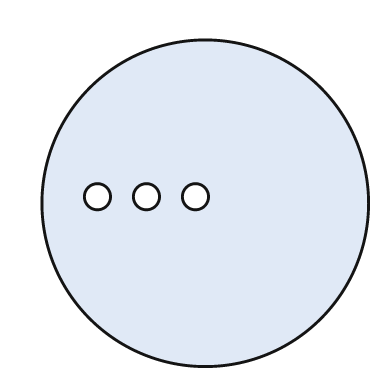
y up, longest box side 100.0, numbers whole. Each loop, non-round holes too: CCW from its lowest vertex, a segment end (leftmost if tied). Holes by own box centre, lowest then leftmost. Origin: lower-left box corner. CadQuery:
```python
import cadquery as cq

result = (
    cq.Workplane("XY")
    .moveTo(50.0, 50.0)
    .circle(50.0)
    .moveTo(17.0, 52.0)
    .circle(4.0)
    .moveTo(32.0, 52.0)
    .circle(4.0)
    .moveTo(47.0, 52.0)
    .circle(4.0)
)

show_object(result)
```